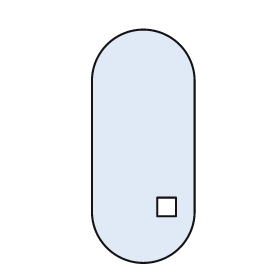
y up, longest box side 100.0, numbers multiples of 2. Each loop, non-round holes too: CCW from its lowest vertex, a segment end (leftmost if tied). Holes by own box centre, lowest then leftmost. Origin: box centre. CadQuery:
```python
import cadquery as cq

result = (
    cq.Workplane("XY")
    .moveTo(-22.0, -28.0)
    .threePointArc((0.0, -50.0), (22.0, -28.0))
    .lineTo(22.0, 28.0)
    .threePointArc((0.0, 50.0), (-22.0, 28.0))
    .close()
    .moveTo(6.0, -30.0)
    .lineTo(14.0, -30.0)
    .lineTo(14.0, -22.0)
    .lineTo(6.0, -22.0)
    .close()
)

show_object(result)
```